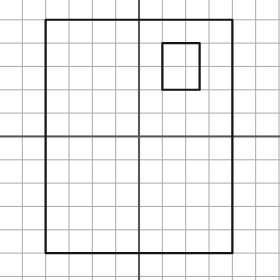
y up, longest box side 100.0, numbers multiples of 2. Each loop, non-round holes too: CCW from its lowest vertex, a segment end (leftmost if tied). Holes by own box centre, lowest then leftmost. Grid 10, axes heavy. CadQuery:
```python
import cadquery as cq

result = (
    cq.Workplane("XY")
    .moveTo(-40.0, -50.0)
    .lineTo(40.0, -50.0)
    .lineTo(40.0, 50.0)
    .lineTo(-40.0, 50.0)
    .close()
    .moveTo(10.0, 20.0)
    .lineTo(26.0, 20.0)
    .lineTo(26.0, 40.0)
    .lineTo(10.0, 40.0)
    .close()
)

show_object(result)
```